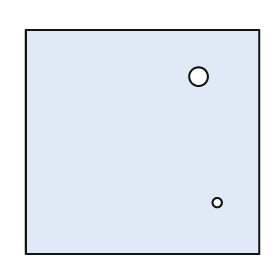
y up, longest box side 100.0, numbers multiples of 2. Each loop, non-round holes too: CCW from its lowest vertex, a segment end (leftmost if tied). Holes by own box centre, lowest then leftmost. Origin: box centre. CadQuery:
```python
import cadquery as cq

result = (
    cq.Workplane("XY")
    .moveTo(-50.0, -48.0)
    .lineTo(50.0, -48.0)
    .lineTo(50.0, 48.0)
    .lineTo(-50.0, 48.0)
    .close()
    .moveTo(32.0, -26.0)
    .circle(2.0)
    .moveTo(24.0, 28.0)
    .circle(4.0)
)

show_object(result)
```